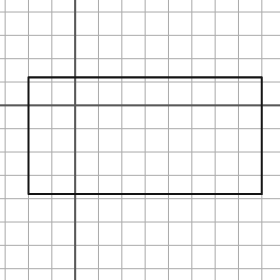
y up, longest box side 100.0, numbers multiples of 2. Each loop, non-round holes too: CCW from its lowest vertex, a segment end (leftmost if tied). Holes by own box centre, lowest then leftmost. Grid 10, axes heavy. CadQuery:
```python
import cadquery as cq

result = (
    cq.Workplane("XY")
    .moveTo(-20.0, -38.0)
    .lineTo(80.0, -38.0)
    .lineTo(80.0, 12.0)
    .lineTo(-20.0, 12.0)
    .close()
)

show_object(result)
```